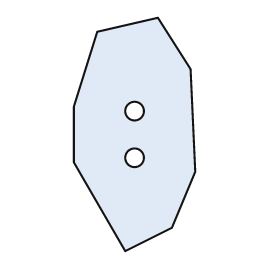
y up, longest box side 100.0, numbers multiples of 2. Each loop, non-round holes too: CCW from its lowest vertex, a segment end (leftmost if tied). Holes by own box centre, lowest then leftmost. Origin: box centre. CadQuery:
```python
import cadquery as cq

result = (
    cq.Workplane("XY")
    .moveTo(-4.0, -50.0)
    .lineTo(16.0, -40.0)
    .lineTo(26.0, -16.0)
    .lineTo(24.0, 28.0)
    .lineTo(10.0, 50.0)
    .lineTo(-16.0, 44.0)
    .lineTo(-26.0, 12.0)
    .lineTo(-26.0, -12.0)
    .close()
    .moveTo(0.0, -10.0)
    .circle(4.0)
    .moveTo(0.0, 10.0)
    .circle(4.0)
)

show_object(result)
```